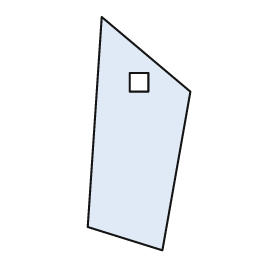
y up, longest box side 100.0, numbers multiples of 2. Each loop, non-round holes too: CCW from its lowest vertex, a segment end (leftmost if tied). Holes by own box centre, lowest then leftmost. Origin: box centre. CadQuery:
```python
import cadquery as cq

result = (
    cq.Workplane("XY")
    .moveTo(10.0, -50.0)
    .lineTo(22.0, 18.0)
    .lineTo(-16.0, 50.0)
    .lineTo(-22.0, -40.0)
    .close()
    .moveTo(-4.0, 18.0)
    .lineTo(4.0, 18.0)
    .lineTo(4.0, 26.0)
    .lineTo(-4.0, 26.0)
    .close()
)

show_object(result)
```